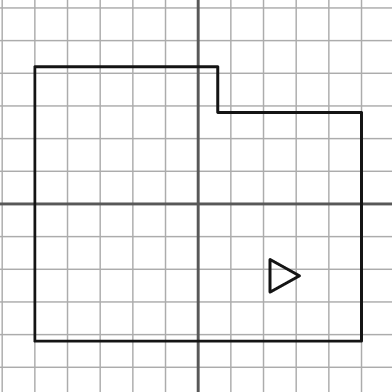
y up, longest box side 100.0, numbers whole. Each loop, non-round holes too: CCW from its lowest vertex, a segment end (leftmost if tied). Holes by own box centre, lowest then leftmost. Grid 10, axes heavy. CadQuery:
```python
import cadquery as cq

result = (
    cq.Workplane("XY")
    .moveTo(-50.0, -42.0)
    .lineTo(50.0, -42.0)
    .lineTo(50.0, 28.0)
    .lineTo(6.0, 28.0)
    .lineTo(6.0, 42.0)
    .lineTo(-50.0, 42.0)
    .close()
    .moveTo(22.0, -27.0)
    .lineTo(31.0, -22.0)
    .lineTo(22.0, -17.0)
    .close()
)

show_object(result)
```